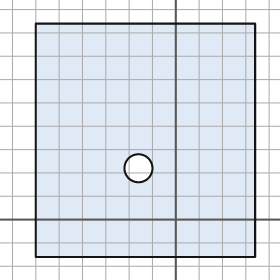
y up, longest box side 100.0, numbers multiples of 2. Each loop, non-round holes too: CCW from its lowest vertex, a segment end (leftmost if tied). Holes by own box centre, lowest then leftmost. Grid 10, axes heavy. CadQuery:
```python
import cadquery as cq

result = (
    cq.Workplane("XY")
    .moveTo(-60.0, -16.0)
    .lineTo(34.0, -16.0)
    .lineTo(34.0, 84.0)
    .lineTo(-60.0, 84.0)
    .close()
    .moveTo(-16.0, 22.0)
    .circle(6.0)
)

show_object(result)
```